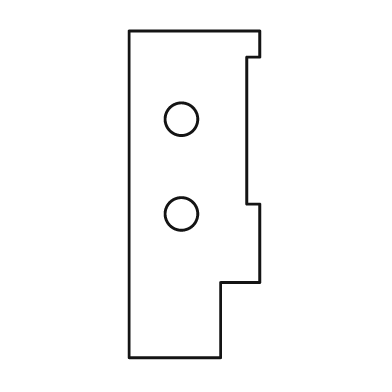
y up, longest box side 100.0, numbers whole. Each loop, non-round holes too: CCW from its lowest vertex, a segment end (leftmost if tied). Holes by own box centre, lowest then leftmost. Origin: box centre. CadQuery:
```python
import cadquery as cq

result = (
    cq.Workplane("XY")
    .moveTo(-20.0, -50.0)
    .lineTo(8.0, -50.0)
    .lineTo(8.0, -27.0)
    .lineTo(20.0, -27.0)
    .lineTo(20.0, -3.0)
    .lineTo(16.0, -3.0)
    .lineTo(16.0, 42.0)
    .lineTo(20.0, 42.0)
    .lineTo(20.0, 50.0)
    .lineTo(-20.0, 50.0)
    .close()
    .moveTo(-4.0, -6.0)
    .circle(5.0)
    .moveTo(-4.0, 23.0)
    .circle(5.0)
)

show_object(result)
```